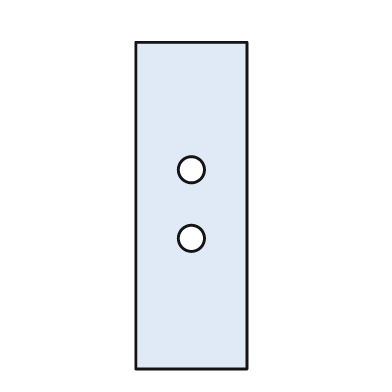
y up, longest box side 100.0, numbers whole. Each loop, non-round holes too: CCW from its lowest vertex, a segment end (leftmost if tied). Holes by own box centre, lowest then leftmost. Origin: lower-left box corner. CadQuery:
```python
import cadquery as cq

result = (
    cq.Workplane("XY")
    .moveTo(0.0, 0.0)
    .lineTo(34.0, 0.0)
    .lineTo(34.0, 100.0)
    .lineTo(0.0, 100.0)
    .close()
    .moveTo(17.0, 40.0)
    .circle(4.0)
    .moveTo(17.0, 61.0)
    .circle(4.0)
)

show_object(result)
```